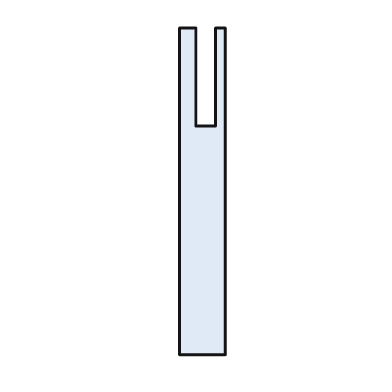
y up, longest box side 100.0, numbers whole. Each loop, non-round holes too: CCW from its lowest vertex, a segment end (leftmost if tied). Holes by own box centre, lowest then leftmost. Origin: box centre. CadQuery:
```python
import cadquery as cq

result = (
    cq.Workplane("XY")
    .moveTo(-7.0, -50.0)
    .lineTo(7.0, -50.0)
    .lineTo(7.0, 50.0)
    .lineTo(4.0, 50.0)
    .lineTo(4.0, 20.0)
    .lineTo(-2.0, 20.0)
    .lineTo(-2.0, 50.0)
    .lineTo(-7.0, 50.0)
    .close()
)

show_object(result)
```